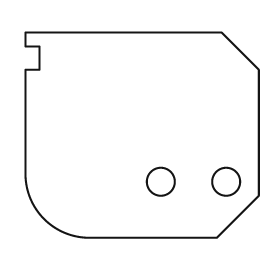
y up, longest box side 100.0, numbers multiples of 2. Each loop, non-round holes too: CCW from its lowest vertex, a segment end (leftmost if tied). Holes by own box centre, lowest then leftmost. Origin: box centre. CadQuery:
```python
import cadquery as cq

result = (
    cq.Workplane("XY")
    .moveTo(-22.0, -44.0)
    .lineTo(32.0, -44.0)
    .lineTo(50.0, -26.0)
    .lineTo(50.0, 28.0)
    .lineTo(34.0, 44.0)
    .lineTo(-50.0, 44.0)
    .lineTo(-50.0, 38.0)
    .lineTo(-44.0, 38.0)
    .lineTo(-44.0, 28.0)
    .lineTo(-50.0, 28.0)
    .lineTo(-50.0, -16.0)
    .threePointArc((-42.0, -36.0), (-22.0, -44.0))
    .close()
    .moveTo(8.0, -20.0)
    .circle(6.0)
    .moveTo(36.0, -20.0)
    .circle(6.0)
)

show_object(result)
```